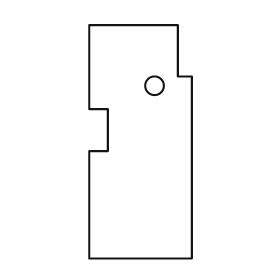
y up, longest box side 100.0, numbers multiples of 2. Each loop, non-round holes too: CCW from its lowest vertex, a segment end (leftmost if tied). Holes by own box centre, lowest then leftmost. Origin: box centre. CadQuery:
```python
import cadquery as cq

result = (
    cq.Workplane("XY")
    .moveTo(-22.0, -50.0)
    .lineTo(22.0, -50.0)
    .lineTo(22.0, 28.0)
    .lineTo(16.0, 28.0)
    .lineTo(16.0, 50.0)
    .lineTo(-22.0, 50.0)
    .lineTo(-22.0, 14.0)
    .lineTo(-14.0, 14.0)
    .lineTo(-14.0, -4.0)
    .lineTo(-22.0, -4.0)
    .close()
    .moveTo(6.0, 24.0)
    .circle(4.0)
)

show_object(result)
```